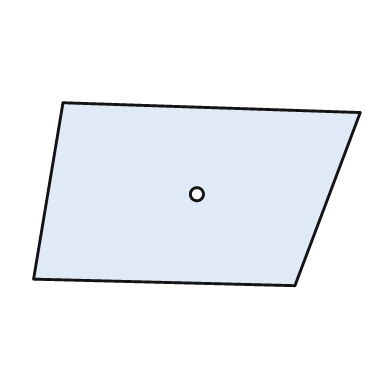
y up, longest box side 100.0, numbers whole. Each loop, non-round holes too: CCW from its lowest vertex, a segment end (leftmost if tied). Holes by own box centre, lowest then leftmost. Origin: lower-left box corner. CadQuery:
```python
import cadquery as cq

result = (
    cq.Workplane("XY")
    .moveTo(80.0, 0.0)
    .lineTo(100.0, 53.0)
    .lineTo(9.0, 56.0)
    .lineTo(0.0, 2.0)
    .close()
    .moveTo(50.0, 28.0)
    .circle(2.0)
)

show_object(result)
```